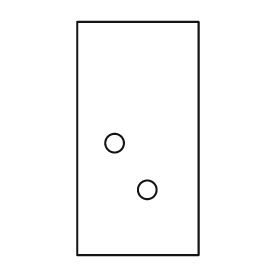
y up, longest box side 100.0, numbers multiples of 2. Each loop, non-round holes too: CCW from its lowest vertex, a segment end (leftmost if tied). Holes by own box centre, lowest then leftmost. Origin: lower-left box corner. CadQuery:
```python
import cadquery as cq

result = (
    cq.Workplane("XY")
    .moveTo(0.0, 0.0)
    .lineTo(52.0, 0.0)
    .lineTo(52.0, 100.0)
    .lineTo(0.0, 100.0)
    .close()
    .moveTo(30.0, 28.0)
    .circle(4.0)
    .moveTo(16.0, 48.0)
    .circle(4.0)
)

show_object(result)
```